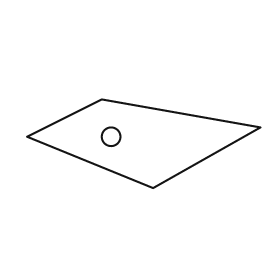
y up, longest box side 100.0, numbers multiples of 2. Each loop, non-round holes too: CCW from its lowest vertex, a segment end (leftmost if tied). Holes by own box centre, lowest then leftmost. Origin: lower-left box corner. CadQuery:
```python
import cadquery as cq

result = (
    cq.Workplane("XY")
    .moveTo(54.0, 0.0)
    .lineTo(100.0, 26.0)
    .lineTo(32.0, 38.0)
    .lineTo(0.0, 22.0)
    .close()
    .moveTo(36.0, 22.0)
    .circle(4.0)
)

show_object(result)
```